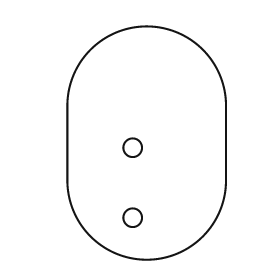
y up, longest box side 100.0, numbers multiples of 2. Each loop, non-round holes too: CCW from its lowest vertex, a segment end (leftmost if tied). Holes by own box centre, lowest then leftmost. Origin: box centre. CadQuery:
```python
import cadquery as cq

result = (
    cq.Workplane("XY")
    .moveTo(-34.0, -16.0)
    .threePointArc((0.0, -50.0), (34.0, -16.0))
    .lineTo(34.0, 16.0)
    .threePointArc((0.0, 50.0), (-34.0, 16.0))
    .close()
    .moveTo(-6.0, -32.0)
    .circle(4.0)
    .moveTo(-6.0, -2.0)
    .circle(4.0)
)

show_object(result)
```